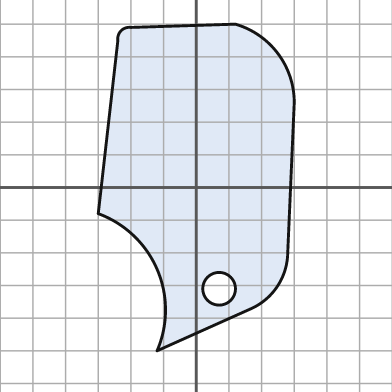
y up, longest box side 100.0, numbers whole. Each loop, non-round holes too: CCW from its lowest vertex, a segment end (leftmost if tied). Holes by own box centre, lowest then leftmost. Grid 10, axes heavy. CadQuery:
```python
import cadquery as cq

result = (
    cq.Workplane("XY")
    .moveTo(-12.0, -50.0)
    .lineTo(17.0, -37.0)
    .threePointArc((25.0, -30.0), (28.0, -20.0))
    .lineTo(30.0, 26.0)
    .threePointArc((25.0, 41.0), (12.0, 50.0))
    .lineTo(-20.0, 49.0)
    .threePointArc((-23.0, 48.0), (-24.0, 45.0))
    .lineTo(-30.0, -8.0)
    .threePointArc((-12.0, -25.0), (-12.0, -50.0))
    .close()
    .moveTo(7.0, -31.0)
    .circle(5.0)
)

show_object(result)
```